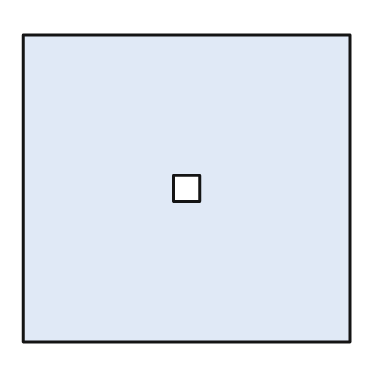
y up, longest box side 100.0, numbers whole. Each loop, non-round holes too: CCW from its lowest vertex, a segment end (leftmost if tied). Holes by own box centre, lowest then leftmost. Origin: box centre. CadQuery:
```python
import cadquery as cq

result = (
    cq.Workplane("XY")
    .moveTo(-50.0, -47.0)
    .lineTo(50.0, -47.0)
    .lineTo(50.0, 47.0)
    .lineTo(-50.0, 47.0)
    .close()
    .moveTo(-4.0, -4.0)
    .lineTo(4.0, -4.0)
    .lineTo(4.0, 4.0)
    .lineTo(-4.0, 4.0)
    .close()
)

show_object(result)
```